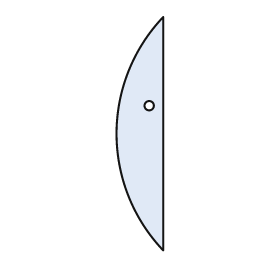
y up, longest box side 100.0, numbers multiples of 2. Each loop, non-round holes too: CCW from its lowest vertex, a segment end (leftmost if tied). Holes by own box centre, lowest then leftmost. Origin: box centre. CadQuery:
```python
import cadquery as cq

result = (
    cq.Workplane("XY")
    .moveTo(10.0, -50.0)
    .lineTo(10.0, 50.0)
    .threePointArc((-10.0, 0.0), (10.0, -50.0))
    .close()
    .moveTo(4.0, 12.0)
    .circle(2.0)
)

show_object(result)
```